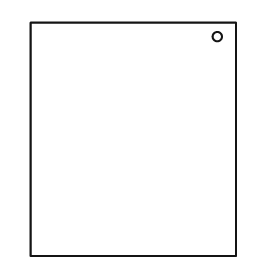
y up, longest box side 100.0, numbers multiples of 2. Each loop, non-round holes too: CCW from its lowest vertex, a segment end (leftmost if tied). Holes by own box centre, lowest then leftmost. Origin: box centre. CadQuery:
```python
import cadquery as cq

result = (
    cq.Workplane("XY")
    .moveTo(-44.0, -50.0)
    .lineTo(44.0, -50.0)
    .lineTo(44.0, 50.0)
    .lineTo(-44.0, 50.0)
    .close()
    .moveTo(36.0, 44.0)
    .circle(2.0)
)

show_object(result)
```